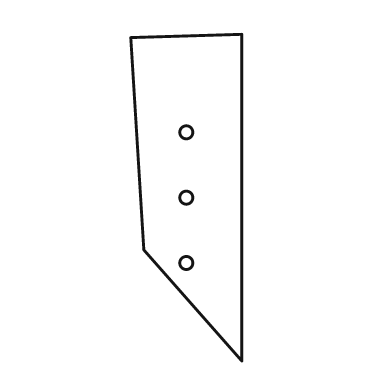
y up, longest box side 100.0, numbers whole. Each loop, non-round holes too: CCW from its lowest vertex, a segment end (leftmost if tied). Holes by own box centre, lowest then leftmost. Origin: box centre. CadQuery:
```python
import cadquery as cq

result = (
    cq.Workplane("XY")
    .moveTo(17.0, -50.0)
    .lineTo(17.0, 50.0)
    .lineTo(-17.0, 49.0)
    .lineTo(-13.0, -16.0)
    .close()
    .moveTo(0.0, -20.0)
    .circle(2.0)
    .moveTo(0.0, 0.0)
    .circle(2.0)
    .moveTo(0.0, 20.0)
    .circle(2.0)
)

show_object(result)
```